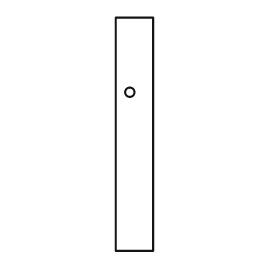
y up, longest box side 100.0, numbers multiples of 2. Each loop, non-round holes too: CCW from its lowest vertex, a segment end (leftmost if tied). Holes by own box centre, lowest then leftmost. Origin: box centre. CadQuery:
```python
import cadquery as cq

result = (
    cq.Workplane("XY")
    .moveTo(-8.0, -50.0)
    .lineTo(8.0, -50.0)
    .lineTo(8.0, 50.0)
    .lineTo(-8.0, 50.0)
    .close()
    .moveTo(-2.0, 18.0)
    .circle(2.0)
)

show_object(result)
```